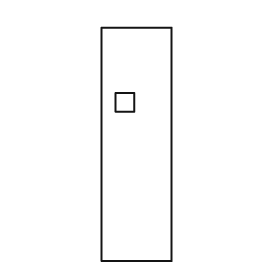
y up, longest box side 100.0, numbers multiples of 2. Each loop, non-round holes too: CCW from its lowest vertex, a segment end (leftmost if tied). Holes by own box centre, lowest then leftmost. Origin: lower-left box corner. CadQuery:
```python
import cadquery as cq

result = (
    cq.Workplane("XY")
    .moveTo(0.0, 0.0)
    .lineTo(30.0, 0.0)
    .lineTo(30.0, 100.0)
    .lineTo(0.0, 100.0)
    .close()
    .moveTo(6.0, 64.0)
    .lineTo(14.0, 64.0)
    .lineTo(14.0, 72.0)
    .lineTo(6.0, 72.0)
    .close()
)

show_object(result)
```